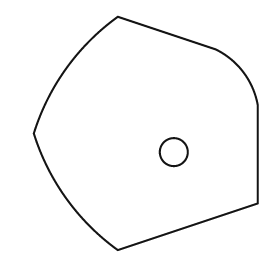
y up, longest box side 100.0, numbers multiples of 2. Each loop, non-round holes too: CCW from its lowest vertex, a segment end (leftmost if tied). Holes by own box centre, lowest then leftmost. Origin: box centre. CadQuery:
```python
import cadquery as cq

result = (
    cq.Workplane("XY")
    .moveTo(-12.0, -50.0)
    .lineTo(48.0, -30.0)
    .lineTo(48.0, 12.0)
    .threePointArc((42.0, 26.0), (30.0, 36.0))
    .lineTo(-12.0, 50.0)
    .threePointArc((-34.0, 28.0), (-48.0, 0.0))
    .threePointArc((-34.0, -28.0), (-12.0, -50.0))
    .close()
    .moveTo(12.0, -8.0)
    .circle(6.0)
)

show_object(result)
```